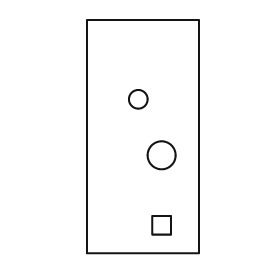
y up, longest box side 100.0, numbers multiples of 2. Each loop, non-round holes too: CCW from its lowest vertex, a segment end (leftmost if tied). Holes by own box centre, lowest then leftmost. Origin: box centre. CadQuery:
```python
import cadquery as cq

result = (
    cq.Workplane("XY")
    .moveTo(-24.0, -50.0)
    .lineTo(24.0, -50.0)
    .lineTo(24.0, 50.0)
    .lineTo(-24.0, 50.0)
    .close()
    .moveTo(4.0, -42.0)
    .lineTo(12.0, -42.0)
    .lineTo(12.0, -34.0)
    .lineTo(4.0, -34.0)
    .close()
    .moveTo(8.0, -8.0)
    .circle(6.0)
    .moveTo(-2.0, 16.0)
    .circle(4.0)
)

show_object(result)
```